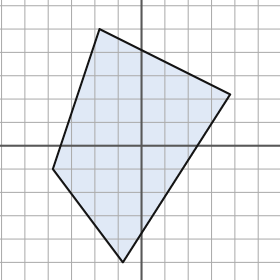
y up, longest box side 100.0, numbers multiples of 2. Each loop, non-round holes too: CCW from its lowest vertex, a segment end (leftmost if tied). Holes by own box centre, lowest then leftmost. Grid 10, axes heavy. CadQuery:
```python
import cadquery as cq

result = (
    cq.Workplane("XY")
    .moveTo(-8.0, -50.0)
    .lineTo(38.0, 22.0)
    .lineTo(-18.0, 50.0)
    .lineTo(-38.0, -10.0)
    .close()
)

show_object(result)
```